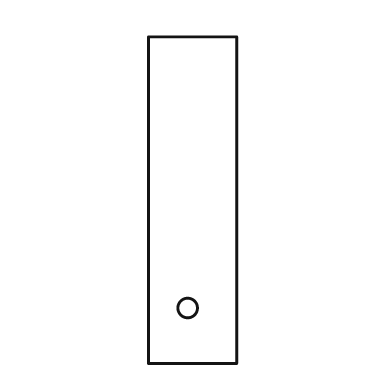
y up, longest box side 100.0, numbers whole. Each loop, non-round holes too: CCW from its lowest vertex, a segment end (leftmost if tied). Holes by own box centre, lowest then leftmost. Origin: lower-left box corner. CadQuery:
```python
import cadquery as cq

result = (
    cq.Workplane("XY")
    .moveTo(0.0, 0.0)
    .lineTo(27.0, 0.0)
    .lineTo(27.0, 100.0)
    .lineTo(0.0, 100.0)
    .close()
    .moveTo(12.0, 17.0)
    .circle(3.0)
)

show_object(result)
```